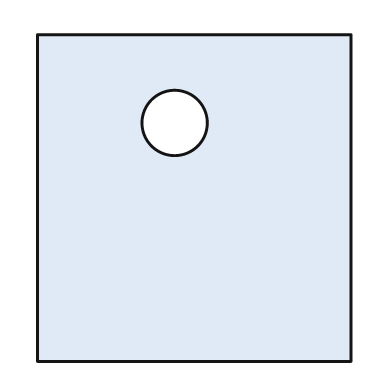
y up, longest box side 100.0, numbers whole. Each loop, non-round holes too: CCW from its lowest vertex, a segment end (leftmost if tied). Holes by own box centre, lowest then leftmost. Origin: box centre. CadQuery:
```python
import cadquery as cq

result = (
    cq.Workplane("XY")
    .moveTo(-48.0, -50.0)
    .lineTo(48.0, -50.0)
    .lineTo(48.0, 50.0)
    .lineTo(-48.0, 50.0)
    .close()
    .moveTo(-6.0, 23.0)
    .circle(10.0)
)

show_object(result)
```